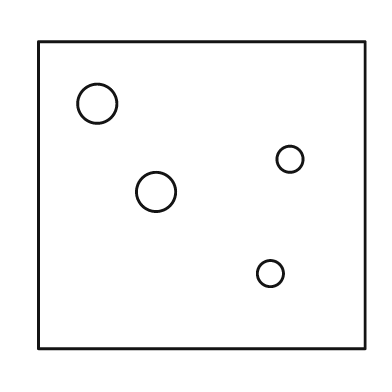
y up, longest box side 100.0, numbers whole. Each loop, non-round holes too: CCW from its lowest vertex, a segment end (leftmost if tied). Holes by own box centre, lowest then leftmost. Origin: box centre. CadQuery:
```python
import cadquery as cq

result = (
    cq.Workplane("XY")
    .moveTo(-50.0, -47.0)
    .lineTo(50.0, -47.0)
    .lineTo(50.0, 47.0)
    .lineTo(-50.0, 47.0)
    .close()
    .moveTo(21.0, -24.0)
    .circle(4.0)
    .moveTo(-14.0, 1.0)
    .circle(6.0)
    .moveTo(27.0, 11.0)
    .circle(4.0)
    .moveTo(-32.0, 28.0)
    .circle(6.0)
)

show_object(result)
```